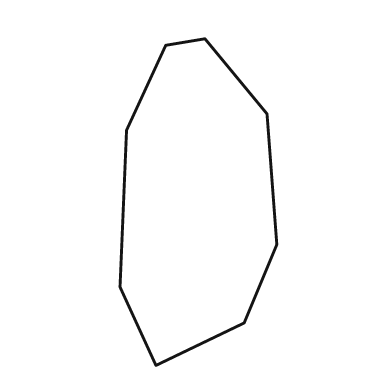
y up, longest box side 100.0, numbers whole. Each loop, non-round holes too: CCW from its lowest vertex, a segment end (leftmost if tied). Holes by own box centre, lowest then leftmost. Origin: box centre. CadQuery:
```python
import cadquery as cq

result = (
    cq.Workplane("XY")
    .moveTo(-13.0, -50.0)
    .lineTo(14.0, -37.0)
    .lineTo(24.0, -13.0)
    .lineTo(21.0, 27.0)
    .lineTo(2.0, 50.0)
    .lineTo(-10.0, 48.0)
    .lineTo(-22.0, 22.0)
    .lineTo(-24.0, -26.0)
    .close()
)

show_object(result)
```